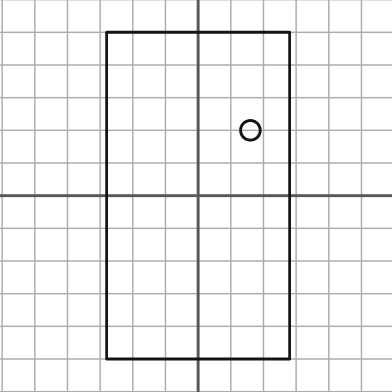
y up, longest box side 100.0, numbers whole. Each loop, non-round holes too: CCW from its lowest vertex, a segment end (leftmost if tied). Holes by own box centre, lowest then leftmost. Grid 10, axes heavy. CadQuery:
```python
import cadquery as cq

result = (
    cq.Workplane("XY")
    .moveTo(-28.0, -50.0)
    .lineTo(28.0, -50.0)
    .lineTo(28.0, 50.0)
    .lineTo(-28.0, 50.0)
    .close()
    .moveTo(16.0, 20.0)
    .circle(3.0)
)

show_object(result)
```